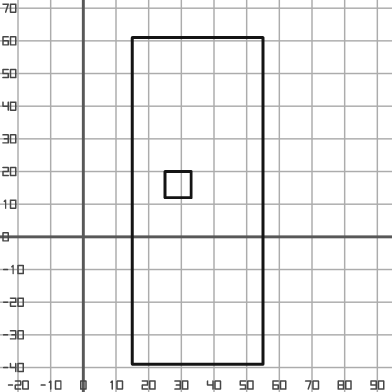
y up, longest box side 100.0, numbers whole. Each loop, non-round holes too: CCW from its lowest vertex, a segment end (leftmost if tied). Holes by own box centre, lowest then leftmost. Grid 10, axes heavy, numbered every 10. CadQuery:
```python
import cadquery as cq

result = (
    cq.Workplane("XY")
    .moveTo(15.0, -39.0)
    .lineTo(55.0, -39.0)
    .lineTo(55.0, 61.0)
    .lineTo(15.0, 61.0)
    .close()
    .moveTo(25.0, 12.0)
    .lineTo(33.0, 12.0)
    .lineTo(33.0, 20.0)
    .lineTo(25.0, 20.0)
    .close()
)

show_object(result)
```